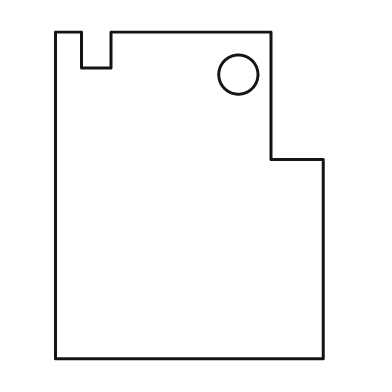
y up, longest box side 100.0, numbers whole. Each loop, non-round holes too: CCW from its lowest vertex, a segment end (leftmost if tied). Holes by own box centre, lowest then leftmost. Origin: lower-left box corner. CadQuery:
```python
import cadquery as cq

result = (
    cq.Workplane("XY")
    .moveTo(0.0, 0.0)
    .lineTo(82.0, 0.0)
    .lineTo(82.0, 61.0)
    .lineTo(66.0, 61.0)
    .lineTo(66.0, 100.0)
    .lineTo(17.0, 100.0)
    .lineTo(17.0, 89.0)
    .lineTo(8.0, 89.0)
    .lineTo(8.0, 100.0)
    .lineTo(0.0, 100.0)
    .close()
    .moveTo(56.0, 87.0)
    .circle(6.0)
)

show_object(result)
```